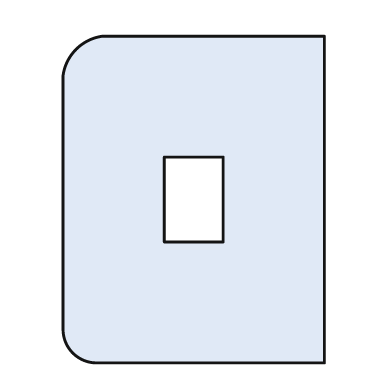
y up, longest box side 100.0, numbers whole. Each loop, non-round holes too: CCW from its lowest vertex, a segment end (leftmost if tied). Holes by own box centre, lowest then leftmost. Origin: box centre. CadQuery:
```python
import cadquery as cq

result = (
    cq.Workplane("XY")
    .moveTo(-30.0, -50.0)
    .lineTo(40.0, -50.0)
    .lineTo(40.0, 50.0)
    .lineTo(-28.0, 50.0)
    .threePointArc((-36.0, 46.0), (-40.0, 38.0))
    .lineTo(-40.0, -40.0)
    .threePointArc((-37.0, -47.0), (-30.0, -50.0))
    .close()
    .moveTo(-9.0, -13.0)
    .lineTo(9.0, -13.0)
    .lineTo(9.0, 13.0)
    .lineTo(-9.0, 13.0)
    .close()
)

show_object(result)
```